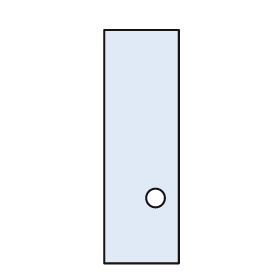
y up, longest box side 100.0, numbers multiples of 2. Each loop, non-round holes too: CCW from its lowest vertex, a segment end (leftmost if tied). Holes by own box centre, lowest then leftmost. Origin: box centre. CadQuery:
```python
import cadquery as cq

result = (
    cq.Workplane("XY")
    .moveTo(-16.0, -50.0)
    .lineTo(16.0, -50.0)
    .lineTo(16.0, 50.0)
    .lineTo(-16.0, 50.0)
    .close()
    .moveTo(6.0, -22.0)
    .circle(4.0)
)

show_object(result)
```